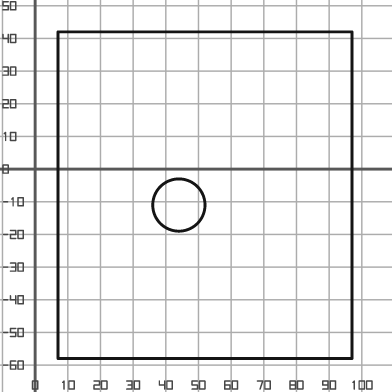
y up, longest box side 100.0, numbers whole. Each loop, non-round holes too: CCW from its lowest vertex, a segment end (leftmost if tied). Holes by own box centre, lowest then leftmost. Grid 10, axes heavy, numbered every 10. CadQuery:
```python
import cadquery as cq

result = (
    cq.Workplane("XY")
    .moveTo(7.0, -58.0)
    .lineTo(97.0, -58.0)
    .lineTo(97.0, 42.0)
    .lineTo(7.0, 42.0)
    .close()
    .moveTo(44.0, -11.0)
    .circle(8.0)
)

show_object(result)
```